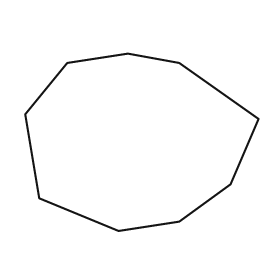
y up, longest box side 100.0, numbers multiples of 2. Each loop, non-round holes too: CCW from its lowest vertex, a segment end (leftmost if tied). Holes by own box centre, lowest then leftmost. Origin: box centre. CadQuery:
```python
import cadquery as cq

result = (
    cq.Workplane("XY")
    .moveTo(-10.0, -38.0)
    .lineTo(16.0, -34.0)
    .lineTo(38.0, -18.0)
    .lineTo(50.0, 10.0)
    .lineTo(16.0, 34.0)
    .lineTo(-6.0, 38.0)
    .lineTo(-32.0, 34.0)
    .lineTo(-50.0, 12.0)
    .lineTo(-44.0, -24.0)
    .close()
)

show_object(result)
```